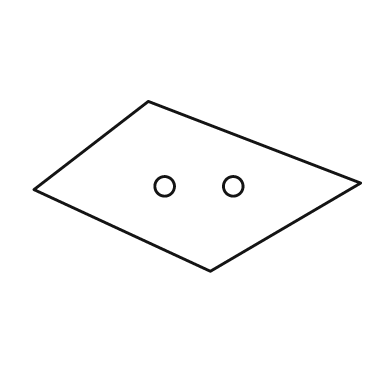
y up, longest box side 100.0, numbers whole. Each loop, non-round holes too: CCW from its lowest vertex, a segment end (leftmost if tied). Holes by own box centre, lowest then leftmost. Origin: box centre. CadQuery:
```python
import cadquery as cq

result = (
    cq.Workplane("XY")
    .moveTo(4.0, -26.0)
    .lineTo(50.0, 1.0)
    .lineTo(-15.0, 26.0)
    .lineTo(-50.0, -1.0)
    .close()
    .moveTo(-10.0, 0.0)
    .circle(3.0)
    .moveTo(11.0, 0.0)
    .circle(3.0)
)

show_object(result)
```